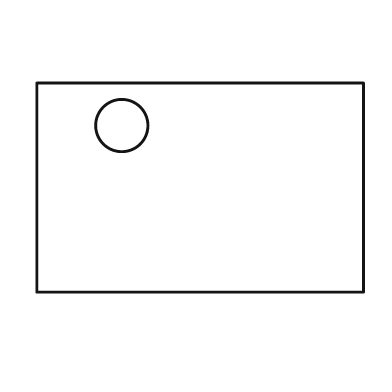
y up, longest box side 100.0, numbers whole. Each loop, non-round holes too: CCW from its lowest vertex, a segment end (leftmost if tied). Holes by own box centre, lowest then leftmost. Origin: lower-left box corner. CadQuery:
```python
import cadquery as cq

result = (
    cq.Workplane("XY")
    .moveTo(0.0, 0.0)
    .lineTo(100.0, 0.0)
    .lineTo(100.0, 64.0)
    .lineTo(0.0, 64.0)
    .close()
    .moveTo(26.0, 51.0)
    .circle(8.0)
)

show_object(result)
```